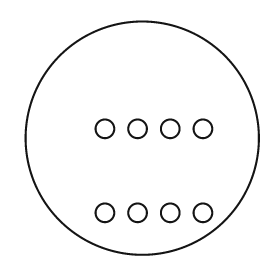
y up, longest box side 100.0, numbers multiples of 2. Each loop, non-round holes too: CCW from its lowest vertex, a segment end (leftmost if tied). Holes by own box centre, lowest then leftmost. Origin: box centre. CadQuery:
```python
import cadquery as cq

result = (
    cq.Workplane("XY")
    .moveTo(0.0, 0.0)
    .circle(50.0)
    .moveTo(-16.0, -32.0)
    .circle(4.0)
    .moveTo(-2.0, -32.0)
    .circle(4.0)
    .moveTo(12.0, -32.0)
    .circle(4.0)
    .moveTo(26.0, -32.0)
    .circle(4.0)
    .moveTo(-16.0, 4.0)
    .circle(4.0)
    .moveTo(-2.0, 4.0)
    .circle(4.0)
    .moveTo(12.0, 4.0)
    .circle(4.0)
    .moveTo(26.0, 4.0)
    .circle(4.0)
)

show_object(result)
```